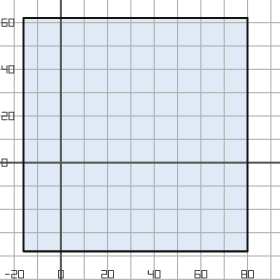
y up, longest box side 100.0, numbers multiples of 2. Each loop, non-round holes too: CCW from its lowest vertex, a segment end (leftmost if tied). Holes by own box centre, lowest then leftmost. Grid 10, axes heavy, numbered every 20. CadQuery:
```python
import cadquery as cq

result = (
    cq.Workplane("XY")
    .moveTo(-16.0, -38.0)
    .lineTo(80.0, -38.0)
    .lineTo(80.0, 62.0)
    .lineTo(-16.0, 62.0)
    .close()
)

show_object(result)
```